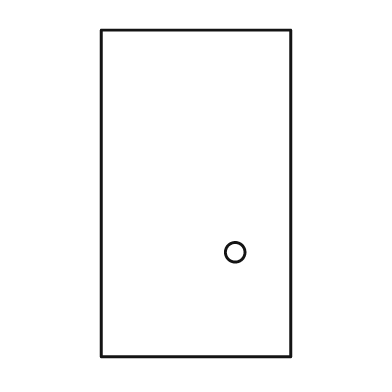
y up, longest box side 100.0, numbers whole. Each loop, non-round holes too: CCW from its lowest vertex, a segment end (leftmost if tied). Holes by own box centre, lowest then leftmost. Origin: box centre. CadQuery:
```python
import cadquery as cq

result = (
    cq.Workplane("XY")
    .moveTo(-29.0, -50.0)
    .lineTo(29.0, -50.0)
    .lineTo(29.0, 50.0)
    .lineTo(-29.0, 50.0)
    .close()
    .moveTo(12.0, -18.0)
    .circle(3.0)
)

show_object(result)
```